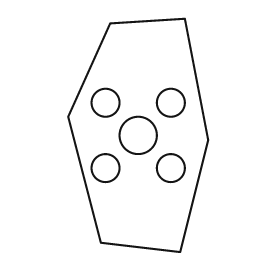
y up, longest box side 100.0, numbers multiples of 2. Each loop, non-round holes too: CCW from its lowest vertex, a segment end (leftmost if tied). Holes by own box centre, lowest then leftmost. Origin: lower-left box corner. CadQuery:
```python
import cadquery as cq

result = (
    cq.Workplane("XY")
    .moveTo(48.0, 0.0)
    .lineTo(60.0, 48.0)
    .lineTo(50.0, 100.0)
    .lineTo(18.0, 98.0)
    .lineTo(0.0, 58.0)
    .lineTo(14.0, 4.0)
    .close()
    .moveTo(16.0, 36.0)
    .circle(6.0)
    .moveTo(44.0, 36.0)
    .circle(6.0)
    .moveTo(30.0, 50.0)
    .circle(8.0)
    .moveTo(16.0, 64.0)
    .circle(6.0)
    .moveTo(44.0, 64.0)
    .circle(6.0)
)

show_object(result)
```